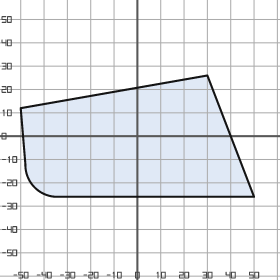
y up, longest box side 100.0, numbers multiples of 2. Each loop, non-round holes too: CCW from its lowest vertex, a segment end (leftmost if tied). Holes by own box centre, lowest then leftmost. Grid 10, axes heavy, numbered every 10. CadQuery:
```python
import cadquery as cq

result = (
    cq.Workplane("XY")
    .moveTo(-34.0, -26.0)
    .lineTo(50.0, -26.0)
    .lineTo(30.0, 26.0)
    .lineTo(-50.0, 12.0)
    .lineTo(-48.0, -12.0)
    .threePointArc((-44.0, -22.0), (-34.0, -26.0))
    .close()
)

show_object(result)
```